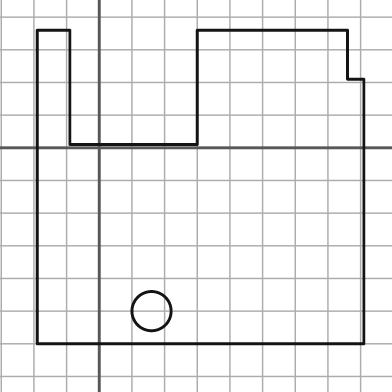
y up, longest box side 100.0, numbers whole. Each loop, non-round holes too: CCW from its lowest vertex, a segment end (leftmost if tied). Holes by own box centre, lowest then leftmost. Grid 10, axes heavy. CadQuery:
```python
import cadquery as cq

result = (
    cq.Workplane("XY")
    .moveTo(-19.0, -60.0)
    .lineTo(81.0, -60.0)
    .lineTo(81.0, 21.0)
    .lineTo(76.0, 21.0)
    .lineTo(76.0, 36.0)
    .lineTo(30.0, 36.0)
    .lineTo(30.0, 1.0)
    .lineTo(-9.0, 1.0)
    .lineTo(-9.0, 36.0)
    .lineTo(-19.0, 36.0)
    .close()
    .moveTo(16.0, -50.0)
    .circle(6.0)
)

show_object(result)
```